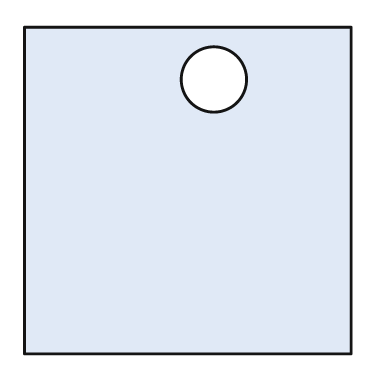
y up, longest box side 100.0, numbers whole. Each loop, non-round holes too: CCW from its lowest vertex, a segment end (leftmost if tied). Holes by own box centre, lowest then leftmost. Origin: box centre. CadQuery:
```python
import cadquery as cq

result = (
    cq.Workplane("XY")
    .moveTo(-50.0, -50.0)
    .lineTo(50.0, -50.0)
    .lineTo(50.0, 50.0)
    .lineTo(-50.0, 50.0)
    .close()
    .moveTo(8.0, 34.0)
    .circle(10.0)
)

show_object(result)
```